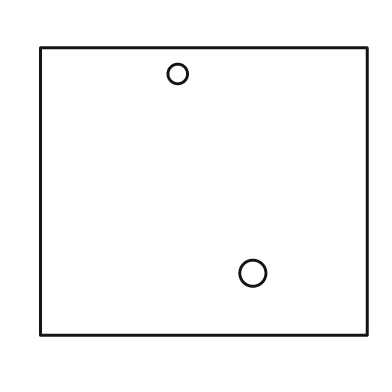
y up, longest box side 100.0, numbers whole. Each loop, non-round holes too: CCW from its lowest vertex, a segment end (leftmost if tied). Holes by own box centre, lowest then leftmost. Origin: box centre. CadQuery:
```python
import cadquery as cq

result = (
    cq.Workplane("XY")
    .moveTo(-50.0, -44.0)
    .lineTo(50.0, -44.0)
    .lineTo(50.0, 44.0)
    .lineTo(-50.0, 44.0)
    .close()
    .moveTo(15.0, -25.0)
    .circle(4.0)
    .moveTo(-8.0, 36.0)
    .circle(3.0)
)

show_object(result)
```